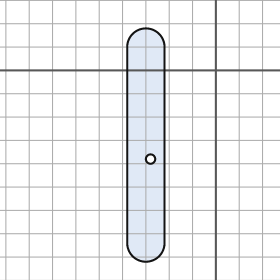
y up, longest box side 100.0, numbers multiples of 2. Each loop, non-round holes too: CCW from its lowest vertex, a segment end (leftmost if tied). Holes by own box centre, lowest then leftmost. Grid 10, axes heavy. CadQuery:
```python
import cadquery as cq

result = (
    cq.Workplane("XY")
    .moveTo(-38.0, -74.0)
    .threePointArc((-30.0, -82.0), (-22.0, -74.0))
    .lineTo(-22.0, 10.0)
    .threePointArc((-30.0, 18.0), (-38.0, 10.0))
    .close()
    .moveTo(-28.0, -38.0)
    .circle(2.0)
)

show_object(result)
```